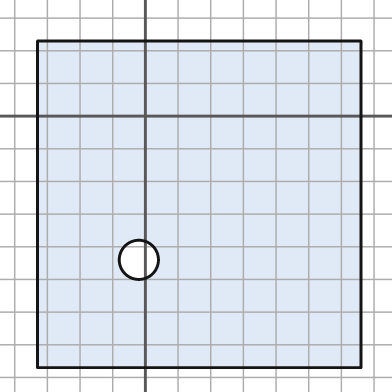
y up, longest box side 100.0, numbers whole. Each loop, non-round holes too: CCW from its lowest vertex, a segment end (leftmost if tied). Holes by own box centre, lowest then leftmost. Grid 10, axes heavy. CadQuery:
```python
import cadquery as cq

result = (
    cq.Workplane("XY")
    .moveTo(-33.0, -77.0)
    .lineTo(66.0, -77.0)
    .lineTo(66.0, 23.0)
    .lineTo(-33.0, 23.0)
    .close()
    .moveTo(-2.0, -44.0)
    .circle(6.0)
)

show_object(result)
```